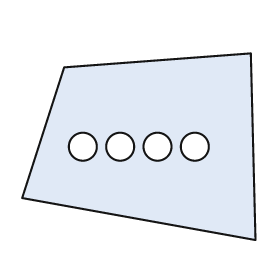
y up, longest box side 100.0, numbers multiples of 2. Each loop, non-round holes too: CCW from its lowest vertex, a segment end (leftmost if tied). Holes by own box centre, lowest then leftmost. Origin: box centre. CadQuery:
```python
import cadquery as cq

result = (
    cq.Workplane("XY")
    .moveTo(50.0, -40.0)
    .lineTo(48.0, 40.0)
    .lineTo(-32.0, 34.0)
    .lineTo(-50.0, -22.0)
    .close()
    .moveTo(-24.0, 0.0)
    .circle(6.0)
    .moveTo(-8.0, 0.0)
    .circle(6.0)
    .moveTo(8.0, 0.0)
    .circle(6.0)
    .moveTo(24.0, 0.0)
    .circle(6.0)
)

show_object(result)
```